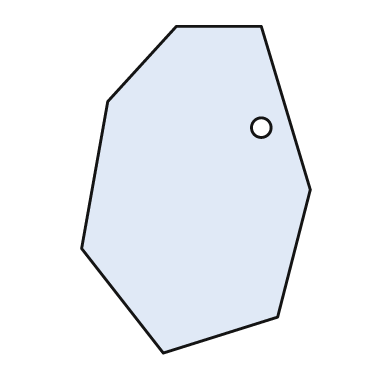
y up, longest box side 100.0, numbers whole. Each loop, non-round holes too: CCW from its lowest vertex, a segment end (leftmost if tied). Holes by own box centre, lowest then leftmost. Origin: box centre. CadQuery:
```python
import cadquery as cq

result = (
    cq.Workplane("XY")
    .moveTo(-10.0, -50.0)
    .lineTo(25.0, -39.0)
    .lineTo(35.0, 0.0)
    .lineTo(20.0, 50.0)
    .lineTo(-6.0, 50.0)
    .lineTo(-27.0, 27.0)
    .lineTo(-35.0, -18.0)
    .close()
    .moveTo(20.0, 19.0)
    .circle(3.0)
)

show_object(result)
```